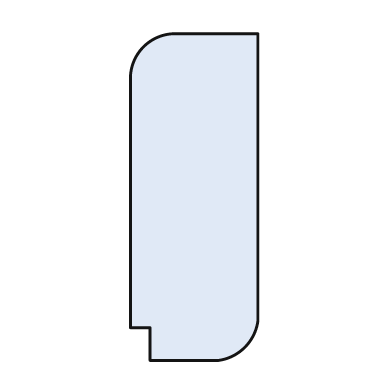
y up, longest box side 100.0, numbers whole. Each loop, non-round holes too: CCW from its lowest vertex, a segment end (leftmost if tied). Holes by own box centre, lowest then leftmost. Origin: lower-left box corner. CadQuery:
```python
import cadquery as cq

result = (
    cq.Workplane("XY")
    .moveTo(6.0, 0.0)
    .lineTo(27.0, 0.0)
    .threePointArc((35.0, 4.0), (39.0, 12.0))
    .lineTo(39.0, 100.0)
    .lineTo(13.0, 100.0)
    .threePointArc((4.0, 96.0), (0.0, 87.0))
    .lineTo(0.0, 10.0)
    .lineTo(6.0, 10.0)
    .close()
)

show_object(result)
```